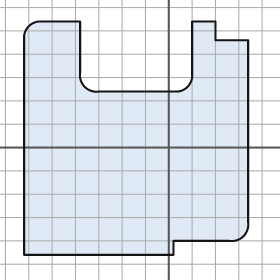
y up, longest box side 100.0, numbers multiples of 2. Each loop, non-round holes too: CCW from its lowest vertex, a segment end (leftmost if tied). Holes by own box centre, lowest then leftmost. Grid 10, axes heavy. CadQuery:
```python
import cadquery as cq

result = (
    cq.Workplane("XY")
    .moveTo(-62.0, -46.0)
    .lineTo(2.0, -46.0)
    .lineTo(2.0, -40.0)
    .lineTo(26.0, -40.0)
    .threePointArc((32.0, -38.0), (34.0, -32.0))
    .lineTo(34.0, 46.0)
    .lineTo(20.0, 46.0)
    .lineTo(20.0, 54.0)
    .lineTo(10.0, 54.0)
    .lineTo(10.0, 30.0)
    .threePointArc((8.0, 26.0), (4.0, 24.0))
    .lineTo(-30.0, 24.0)
    .threePointArc((-36.0, 26.0), (-38.0, 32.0))
    .lineTo(-38.0, 54.0)
    .lineTo(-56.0, 54.0)
    .threePointArc((-60.0, 52.0), (-62.0, 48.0))
    .close()
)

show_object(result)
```